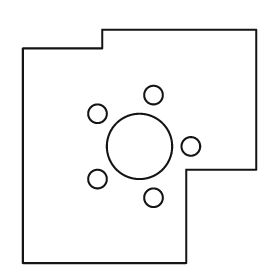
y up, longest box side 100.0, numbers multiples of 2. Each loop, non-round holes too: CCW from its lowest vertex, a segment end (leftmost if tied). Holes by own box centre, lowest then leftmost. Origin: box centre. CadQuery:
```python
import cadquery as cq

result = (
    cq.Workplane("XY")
    .moveTo(-50.0, -50.0)
    .lineTo(20.0, -50.0)
    .lineTo(20.0, -10.0)
    .lineTo(50.0, -10.0)
    .lineTo(50.0, 50.0)
    .lineTo(-16.0, 50.0)
    .lineTo(-16.0, 42.0)
    .lineTo(-50.0, 42.0)
    .close()
    .moveTo(6.0, -22.0)
    .circle(4.0)
    .moveTo(-18.0, -14.0)
    .circle(4.0)
    .moveTo(0.0, 0.0)
    .circle(14.0)
    .moveTo(22.0, 0.0)
    .circle(4.0)
    .moveTo(-18.0, 14.0)
    .circle(4.0)
    .moveTo(6.0, 22.0)
    .circle(4.0)
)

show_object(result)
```